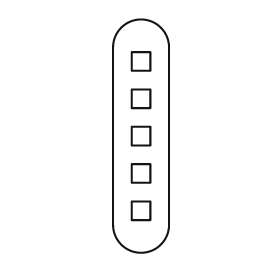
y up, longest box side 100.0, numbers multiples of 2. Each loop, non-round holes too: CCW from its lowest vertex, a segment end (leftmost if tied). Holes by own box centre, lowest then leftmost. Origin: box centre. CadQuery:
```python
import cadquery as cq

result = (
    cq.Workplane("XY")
    .moveTo(-12.0, -38.0)
    .threePointArc((0.0, -50.0), (12.0, -38.0))
    .lineTo(12.0, 38.0)
    .threePointArc((0.0, 50.0), (-12.0, 38.0))
    .close()
    .moveTo(-4.0, -36.0)
    .lineTo(4.0, -36.0)
    .lineTo(4.0, -28.0)
    .lineTo(-4.0, -28.0)
    .close()
    .moveTo(-4.0, -20.0)
    .lineTo(4.0, -20.0)
    .lineTo(4.0, -12.0)
    .lineTo(-4.0, -12.0)
    .close()
    .moveTo(-4.0, -4.0)
    .lineTo(4.0, -4.0)
    .lineTo(4.0, 4.0)
    .lineTo(-4.0, 4.0)
    .close()
    .moveTo(-4.0, 12.0)
    .lineTo(4.0, 12.0)
    .lineTo(4.0, 20.0)
    .lineTo(-4.0, 20.0)
    .close()
    .moveTo(-4.0, 28.0)
    .lineTo(4.0, 28.0)
    .lineTo(4.0, 36.0)
    .lineTo(-4.0, 36.0)
    .close()
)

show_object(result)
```